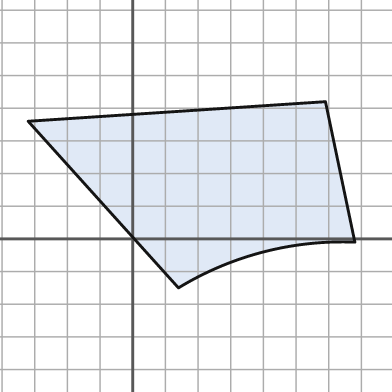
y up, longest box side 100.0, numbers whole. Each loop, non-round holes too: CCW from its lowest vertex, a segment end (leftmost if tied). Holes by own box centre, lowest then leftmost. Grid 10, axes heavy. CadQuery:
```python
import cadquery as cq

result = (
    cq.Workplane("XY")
    .moveTo(14.0, -15.0)
    .threePointArc((40.0, -4.0), (68.0, -1.0))
    .lineTo(59.0, 42.0)
    .lineTo(-32.0, 36.0)
    .close()
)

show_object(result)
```